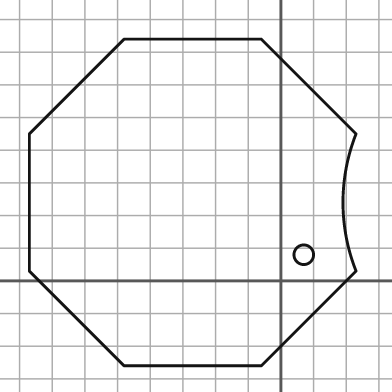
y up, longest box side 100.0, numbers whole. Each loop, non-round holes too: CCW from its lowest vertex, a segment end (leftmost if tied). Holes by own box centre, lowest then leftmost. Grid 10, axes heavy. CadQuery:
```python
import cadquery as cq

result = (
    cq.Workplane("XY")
    .moveTo(-48.0, -26.0)
    .lineTo(-6.0, -26.0)
    .lineTo(23.0, 3.0)
    .threePointArc((19.0, 24.0), (23.0, 45.0))
    .lineTo(-6.0, 74.0)
    .lineTo(-48.0, 74.0)
    .lineTo(-77.0, 45.0)
    .lineTo(-77.0, 3.0)
    .close()
    .moveTo(7.0, 8.0)
    .circle(3.0)
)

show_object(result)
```